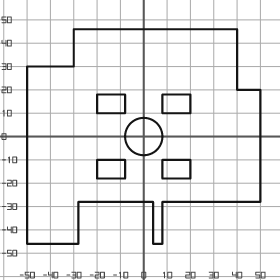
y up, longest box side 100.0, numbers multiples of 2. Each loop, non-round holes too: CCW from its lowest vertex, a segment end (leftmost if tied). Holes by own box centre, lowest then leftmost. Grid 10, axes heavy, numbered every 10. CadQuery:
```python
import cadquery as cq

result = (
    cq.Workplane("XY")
    .moveTo(-50.0, -46.0)
    .lineTo(-28.0, -46.0)
    .lineTo(-28.0, -28.0)
    .lineTo(4.0, -28.0)
    .lineTo(4.0, -46.0)
    .lineTo(8.0, -46.0)
    .lineTo(8.0, -28.0)
    .lineTo(50.0, -28.0)
    .lineTo(50.0, 20.0)
    .lineTo(40.0, 20.0)
    .lineTo(40.0, 46.0)
    .lineTo(-30.0, 46.0)
    .lineTo(-30.0, 30.0)
    .lineTo(-50.0, 30.0)
    .close()
    .moveTo(-20.0, -18.0)
    .lineTo(-8.0, -18.0)
    .lineTo(-8.0, -10.0)
    .lineTo(-20.0, -10.0)
    .close()
    .moveTo(8.0, -18.0)
    .lineTo(20.0, -18.0)
    .lineTo(20.0, -10.0)
    .lineTo(8.0, -10.0)
    .close()
    .moveTo(0.0, 0.0)
    .circle(8.0)
    .moveTo(-20.0, 10.0)
    .lineTo(-8.0, 10.0)
    .lineTo(-8.0, 18.0)
    .lineTo(-20.0, 18.0)
    .close()
    .moveTo(8.0, 10.0)
    .lineTo(20.0, 10.0)
    .lineTo(20.0, 18.0)
    .lineTo(8.0, 18.0)
    .close()
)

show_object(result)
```